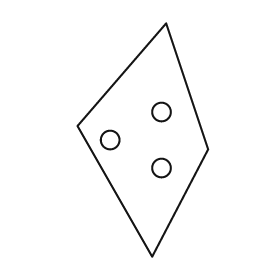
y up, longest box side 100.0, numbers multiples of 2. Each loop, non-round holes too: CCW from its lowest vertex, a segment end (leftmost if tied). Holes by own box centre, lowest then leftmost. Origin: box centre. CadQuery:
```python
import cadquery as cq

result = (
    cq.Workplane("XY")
    .moveTo(4.0, -50.0)
    .lineTo(28.0, -4.0)
    .lineTo(10.0, 50.0)
    .lineTo(-28.0, 6.0)
    .close()
    .moveTo(8.0, -12.0)
    .circle(4.0)
    .moveTo(-14.0, 0.0)
    .circle(4.0)
    .moveTo(8.0, 12.0)
    .circle(4.0)
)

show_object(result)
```